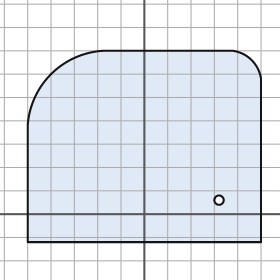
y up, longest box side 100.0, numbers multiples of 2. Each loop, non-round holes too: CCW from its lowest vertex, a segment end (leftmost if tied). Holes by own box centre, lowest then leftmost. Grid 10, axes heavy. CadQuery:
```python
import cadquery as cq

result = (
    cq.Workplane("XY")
    .moveTo(-50.0, -12.0)
    .lineTo(50.0, -12.0)
    .lineTo(50.0, 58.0)
    .threePointArc((46.0, 66.0), (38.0, 70.0))
    .lineTo(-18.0, 70.0)
    .threePointArc((-40.0, 60.0), (-50.0, 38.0))
    .close()
    .moveTo(32.0, 6.0)
    .circle(2.0)
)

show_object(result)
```